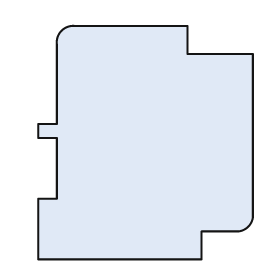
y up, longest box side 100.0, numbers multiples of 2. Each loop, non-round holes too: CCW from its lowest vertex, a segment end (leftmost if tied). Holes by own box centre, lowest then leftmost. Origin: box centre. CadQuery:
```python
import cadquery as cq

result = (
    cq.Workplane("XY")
    .moveTo(-46.0, -50.0)
    .lineTo(24.0, -50.0)
    .lineTo(24.0, -38.0)
    .lineTo(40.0, -38.0)
    .threePointArc((44.0, -36.0), (46.0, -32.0))
    .lineTo(46.0, 38.0)
    .lineTo(18.0, 38.0)
    .lineTo(18.0, 50.0)
    .lineTo(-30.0, 50.0)
    .threePointArc((-36.0, 48.0), (-38.0, 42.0))
    .lineTo(-38.0, 8.0)
    .lineTo(-46.0, 8.0)
    .lineTo(-46.0, 2.0)
    .lineTo(-38.0, 2.0)
    .lineTo(-38.0, -24.0)
    .lineTo(-46.0, -24.0)
    .close()
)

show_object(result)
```